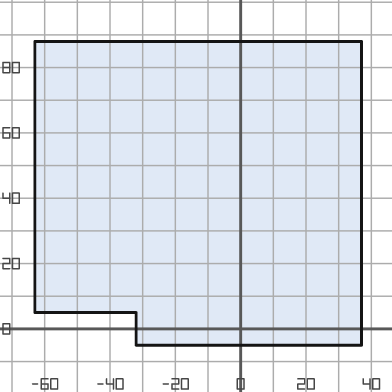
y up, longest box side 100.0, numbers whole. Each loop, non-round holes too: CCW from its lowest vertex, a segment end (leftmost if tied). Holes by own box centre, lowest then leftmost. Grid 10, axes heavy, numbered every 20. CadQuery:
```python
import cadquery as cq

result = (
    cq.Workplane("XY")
    .moveTo(-32.0, -5.0)
    .lineTo(37.0, -5.0)
    .lineTo(37.0, 88.0)
    .lineTo(-63.0, 88.0)
    .lineTo(-63.0, 5.0)
    .lineTo(-32.0, 5.0)
    .close()
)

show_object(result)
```